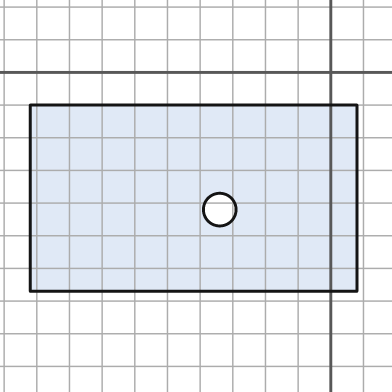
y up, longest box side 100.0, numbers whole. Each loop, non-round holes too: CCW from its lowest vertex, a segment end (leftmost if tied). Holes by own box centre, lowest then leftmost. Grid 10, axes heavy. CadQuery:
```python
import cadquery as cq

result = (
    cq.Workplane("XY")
    .moveTo(-92.0, -67.0)
    .lineTo(8.0, -67.0)
    .lineTo(8.0, -10.0)
    .lineTo(-92.0, -10.0)
    .close()
    .moveTo(-34.0, -42.0)
    .circle(5.0)
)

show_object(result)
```